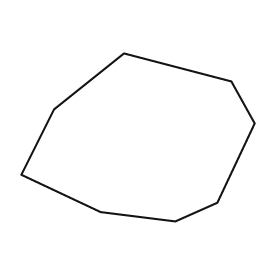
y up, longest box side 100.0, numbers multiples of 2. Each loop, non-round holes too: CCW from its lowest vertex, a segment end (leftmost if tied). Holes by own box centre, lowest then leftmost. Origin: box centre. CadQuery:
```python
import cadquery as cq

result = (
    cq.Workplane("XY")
    .moveTo(16.0, -36.0)
    .lineTo(34.0, -28.0)
    .lineTo(50.0, 6.0)
    .lineTo(40.0, 24.0)
    .lineTo(-6.0, 36.0)
    .lineTo(-36.0, 12.0)
    .lineTo(-50.0, -16.0)
    .lineTo(-16.0, -32.0)
    .close()
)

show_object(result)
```